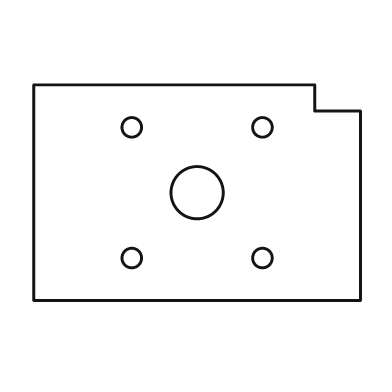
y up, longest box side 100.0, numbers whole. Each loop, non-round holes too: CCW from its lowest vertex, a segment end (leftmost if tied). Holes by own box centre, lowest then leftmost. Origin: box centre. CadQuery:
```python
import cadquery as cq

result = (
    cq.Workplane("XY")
    .moveTo(-50.0, -33.0)
    .lineTo(50.0, -33.0)
    .lineTo(50.0, 25.0)
    .lineTo(36.0, 25.0)
    .lineTo(36.0, 33.0)
    .lineTo(-50.0, 33.0)
    .close()
    .moveTo(-20.0, -20.0)
    .circle(3.0)
    .moveTo(20.0, -20.0)
    .circle(3.0)
    .moveTo(0.0, 0.0)
    .circle(8.0)
    .moveTo(-20.0, 20.0)
    .circle(3.0)
    .moveTo(20.0, 20.0)
    .circle(3.0)
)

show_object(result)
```